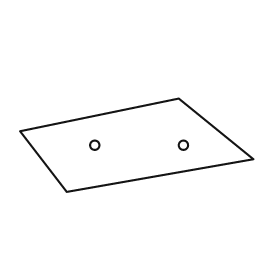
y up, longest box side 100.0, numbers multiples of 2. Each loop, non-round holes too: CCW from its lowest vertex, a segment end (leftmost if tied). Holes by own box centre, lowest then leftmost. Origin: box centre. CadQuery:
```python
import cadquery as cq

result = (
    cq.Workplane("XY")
    .moveTo(-30.0, -20.0)
    .lineTo(50.0, -6.0)
    .lineTo(18.0, 20.0)
    .lineTo(-50.0, 6.0)
    .close()
    .moveTo(-18.0, 0.0)
    .circle(2.0)
    .moveTo(20.0, 0.0)
    .circle(2.0)
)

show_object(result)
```